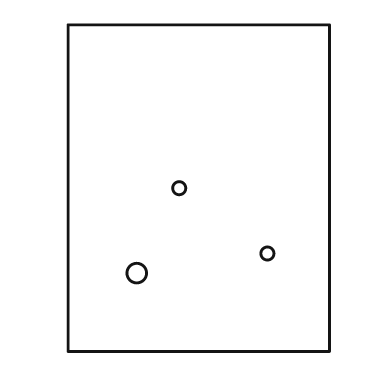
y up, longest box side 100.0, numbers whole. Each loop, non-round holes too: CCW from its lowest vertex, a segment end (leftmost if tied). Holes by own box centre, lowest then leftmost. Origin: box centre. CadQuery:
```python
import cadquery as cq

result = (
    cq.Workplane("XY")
    .moveTo(-40.0, -50.0)
    .lineTo(40.0, -50.0)
    .lineTo(40.0, 50.0)
    .lineTo(-40.0, 50.0)
    .close()
    .moveTo(-19.0, -26.0)
    .circle(3.0)
    .moveTo(21.0, -20.0)
    .circle(2.0)
    .moveTo(-6.0, 0.0)
    .circle(2.0)
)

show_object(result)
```